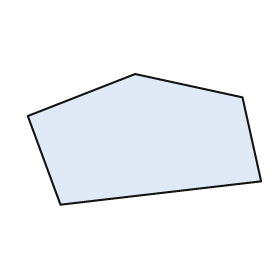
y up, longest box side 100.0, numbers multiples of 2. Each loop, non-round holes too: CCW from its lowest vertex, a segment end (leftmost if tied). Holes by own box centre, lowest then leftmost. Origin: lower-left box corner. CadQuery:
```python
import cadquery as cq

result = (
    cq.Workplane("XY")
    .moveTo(14.0, 0.0)
    .lineTo(100.0, 10.0)
    .lineTo(92.0, 46.0)
    .lineTo(46.0, 56.0)
    .lineTo(0.0, 38.0)
    .close()
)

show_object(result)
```